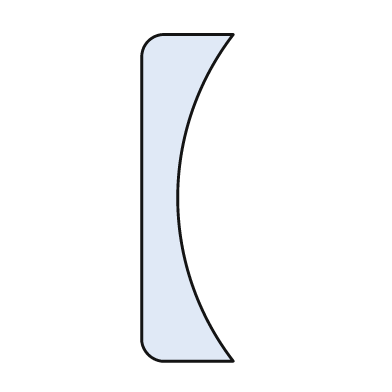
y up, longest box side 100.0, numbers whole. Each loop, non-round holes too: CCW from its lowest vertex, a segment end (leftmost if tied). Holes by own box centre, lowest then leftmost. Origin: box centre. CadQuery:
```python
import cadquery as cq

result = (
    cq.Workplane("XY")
    .moveTo(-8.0, -50.0)
    .lineTo(14.0, -50.0)
    .threePointArc((-3.0, 0.0), (14.0, 50.0))
    .lineTo(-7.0, 50.0)
    .threePointArc((-12.0, 48.0), (-14.0, 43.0))
    .lineTo(-14.0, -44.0)
    .threePointArc((-12.0, -48.0), (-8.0, -50.0))
    .close()
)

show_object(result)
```